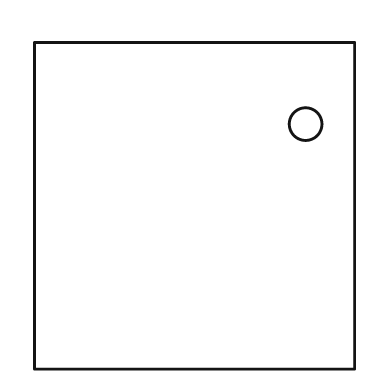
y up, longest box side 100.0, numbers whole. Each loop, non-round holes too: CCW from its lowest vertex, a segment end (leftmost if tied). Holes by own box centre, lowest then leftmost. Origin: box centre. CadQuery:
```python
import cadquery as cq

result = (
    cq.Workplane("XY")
    .moveTo(-49.0, -50.0)
    .lineTo(49.0, -50.0)
    .lineTo(49.0, 50.0)
    .lineTo(-49.0, 50.0)
    .close()
    .moveTo(34.0, 25.0)
    .circle(5.0)
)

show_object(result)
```